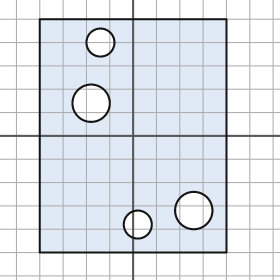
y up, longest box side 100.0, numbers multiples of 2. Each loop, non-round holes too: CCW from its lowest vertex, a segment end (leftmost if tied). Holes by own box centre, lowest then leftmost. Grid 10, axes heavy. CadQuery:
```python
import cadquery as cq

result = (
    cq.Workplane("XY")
    .moveTo(-40.0, -50.0)
    .lineTo(40.0, -50.0)
    .lineTo(40.0, 50.0)
    .lineTo(-40.0, 50.0)
    .close()
    .moveTo(2.0, -38.0)
    .circle(6.0)
    .moveTo(26.0, -32.0)
    .circle(8.0)
    .moveTo(-18.0, 14.0)
    .circle(8.0)
    .moveTo(-14.0, 40.0)
    .circle(6.0)
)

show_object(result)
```